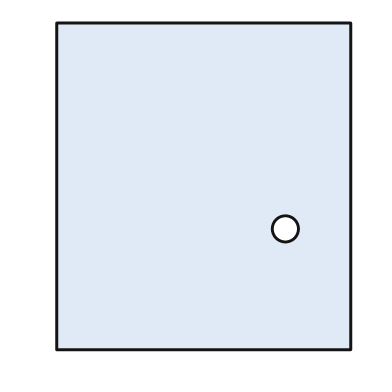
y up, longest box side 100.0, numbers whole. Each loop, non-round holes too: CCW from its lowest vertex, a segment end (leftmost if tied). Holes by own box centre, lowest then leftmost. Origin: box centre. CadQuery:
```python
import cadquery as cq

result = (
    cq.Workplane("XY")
    .moveTo(-45.0, -50.0)
    .lineTo(45.0, -50.0)
    .lineTo(45.0, 50.0)
    .lineTo(-45.0, 50.0)
    .close()
    .moveTo(25.0, -13.0)
    .circle(4.0)
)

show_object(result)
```